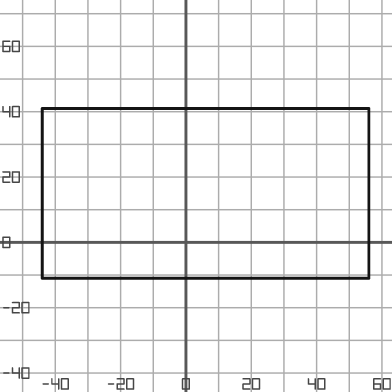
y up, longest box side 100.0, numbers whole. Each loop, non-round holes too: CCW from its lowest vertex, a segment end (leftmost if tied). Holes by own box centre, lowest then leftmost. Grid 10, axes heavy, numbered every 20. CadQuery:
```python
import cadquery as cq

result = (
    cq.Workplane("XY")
    .moveTo(-44.0, -11.0)
    .lineTo(56.0, -11.0)
    .lineTo(56.0, 41.0)
    .lineTo(-44.0, 41.0)
    .close()
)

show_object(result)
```